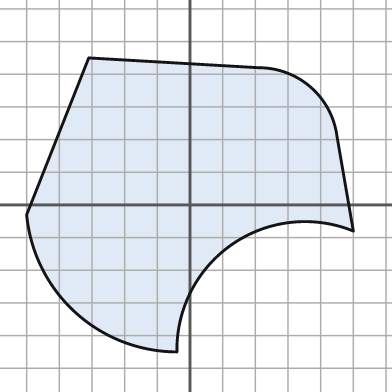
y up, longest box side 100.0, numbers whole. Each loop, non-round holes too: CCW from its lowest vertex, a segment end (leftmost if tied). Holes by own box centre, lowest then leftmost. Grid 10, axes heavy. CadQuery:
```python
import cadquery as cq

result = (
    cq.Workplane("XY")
    .moveTo(-4.0, -45.0)
    .threePointArc((13.0, -12.0), (50.0, -8.0))
    .lineTo(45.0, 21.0)
    .threePointArc((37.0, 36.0), (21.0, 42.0))
    .lineTo(-31.0, 45.0)
    .lineTo(-50.0, -3.0)
    .threePointArc((-35.0, -33.0), (-4.0, -45.0))
    .close()
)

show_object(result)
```